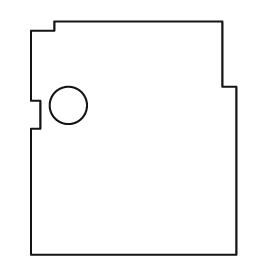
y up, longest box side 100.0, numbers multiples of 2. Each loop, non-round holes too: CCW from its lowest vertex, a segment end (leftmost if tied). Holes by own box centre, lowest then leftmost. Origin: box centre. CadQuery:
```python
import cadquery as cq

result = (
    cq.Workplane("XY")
    .moveTo(-44.0, -50.0)
    .lineTo(44.0, -50.0)
    .lineTo(44.0, 22.0)
    .lineTo(38.0, 22.0)
    .lineTo(38.0, 50.0)
    .lineTo(-34.0, 50.0)
    .lineTo(-34.0, 46.0)
    .lineTo(-44.0, 46.0)
    .lineTo(-44.0, 16.0)
    .lineTo(-40.0, 16.0)
    .lineTo(-40.0, 4.0)
    .lineTo(-44.0, 4.0)
    .close()
    .moveTo(-28.0, 14.0)
    .circle(8.0)
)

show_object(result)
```